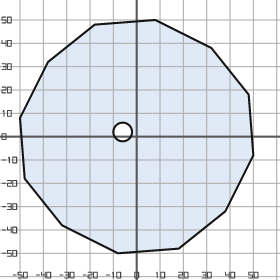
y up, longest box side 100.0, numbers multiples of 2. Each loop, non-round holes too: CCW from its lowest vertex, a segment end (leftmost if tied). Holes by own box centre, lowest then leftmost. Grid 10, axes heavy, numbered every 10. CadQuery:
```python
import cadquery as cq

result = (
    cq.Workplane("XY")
    .moveTo(-8.0, -50.0)
    .lineTo(18.0, -48.0)
    .lineTo(38.0, -32.0)
    .lineTo(50.0, -8.0)
    .lineTo(48.0, 18.0)
    .lineTo(32.0, 38.0)
    .lineTo(8.0, 50.0)
    .lineTo(-18.0, 48.0)
    .lineTo(-38.0, 32.0)
    .lineTo(-50.0, 8.0)
    .lineTo(-48.0, -18.0)
    .lineTo(-32.0, -38.0)
    .close()
    .moveTo(-6.0, 2.0)
    .circle(4.0)
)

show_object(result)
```